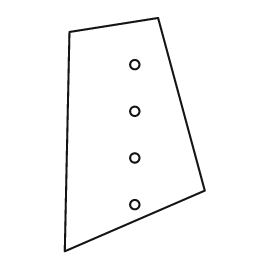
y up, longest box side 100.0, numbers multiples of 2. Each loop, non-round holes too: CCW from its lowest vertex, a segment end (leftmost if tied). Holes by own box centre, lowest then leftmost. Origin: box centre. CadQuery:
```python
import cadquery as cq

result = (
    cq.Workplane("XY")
    .moveTo(-30.0, -50.0)
    .lineTo(30.0, -24.0)
    .lineTo(10.0, 50.0)
    .lineTo(-28.0, 44.0)
    .close()
    .moveTo(0.0, -30.0)
    .circle(2.0)
    .moveTo(0.0, -10.0)
    .circle(2.0)
    .moveTo(0.0, 10.0)
    .circle(2.0)
    .moveTo(0.0, 30.0)
    .circle(2.0)
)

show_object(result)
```